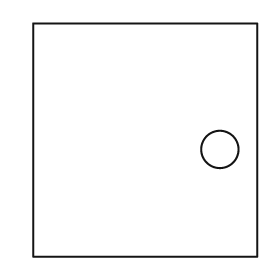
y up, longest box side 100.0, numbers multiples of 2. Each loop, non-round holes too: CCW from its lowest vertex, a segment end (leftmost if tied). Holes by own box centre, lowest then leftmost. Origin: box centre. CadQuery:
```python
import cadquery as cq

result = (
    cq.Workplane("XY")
    .moveTo(-48.0, -50.0)
    .lineTo(48.0, -50.0)
    .lineTo(48.0, 50.0)
    .lineTo(-48.0, 50.0)
    .close()
    .moveTo(32.0, -4.0)
    .circle(8.0)
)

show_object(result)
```